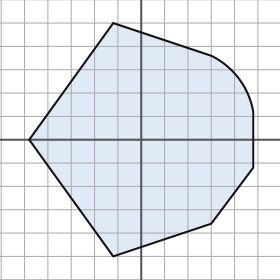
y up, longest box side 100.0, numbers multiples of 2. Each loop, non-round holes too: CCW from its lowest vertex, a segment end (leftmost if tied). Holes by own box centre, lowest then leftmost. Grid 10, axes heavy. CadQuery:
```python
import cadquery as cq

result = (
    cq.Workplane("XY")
    .moveTo(-12.0, -50.0)
    .lineTo(30.0, -36.0)
    .lineTo(48.0, -12.0)
    .lineTo(48.0, 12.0)
    .threePointArc((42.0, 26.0), (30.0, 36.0))
    .lineTo(-12.0, 50.0)
    .lineTo(-48.0, 0.0)
    .close()
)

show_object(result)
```